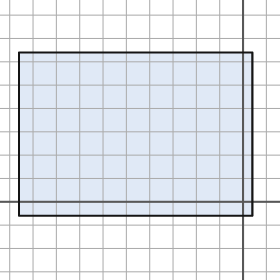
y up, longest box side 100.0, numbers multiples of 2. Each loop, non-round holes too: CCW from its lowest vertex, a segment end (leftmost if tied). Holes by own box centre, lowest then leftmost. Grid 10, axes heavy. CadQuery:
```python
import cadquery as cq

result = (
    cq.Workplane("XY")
    .moveTo(-96.0, -6.0)
    .lineTo(4.0, -6.0)
    .lineTo(4.0, 64.0)
    .lineTo(-96.0, 64.0)
    .close()
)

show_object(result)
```